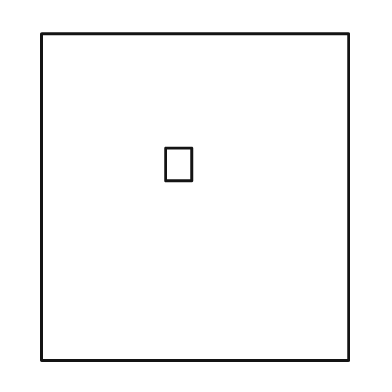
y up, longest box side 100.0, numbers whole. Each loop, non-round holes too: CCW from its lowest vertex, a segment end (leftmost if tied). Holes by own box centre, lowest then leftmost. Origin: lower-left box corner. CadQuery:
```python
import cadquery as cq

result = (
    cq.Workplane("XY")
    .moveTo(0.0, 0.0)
    .lineTo(94.0, 0.0)
    .lineTo(94.0, 100.0)
    .lineTo(0.0, 100.0)
    .close()
    .moveTo(38.0, 55.0)
    .lineTo(46.0, 55.0)
    .lineTo(46.0, 65.0)
    .lineTo(38.0, 65.0)
    .close()
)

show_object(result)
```